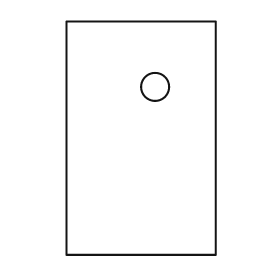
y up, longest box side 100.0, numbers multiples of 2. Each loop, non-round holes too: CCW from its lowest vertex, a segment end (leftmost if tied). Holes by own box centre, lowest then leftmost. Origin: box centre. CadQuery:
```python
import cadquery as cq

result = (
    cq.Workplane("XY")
    .moveTo(-32.0, -50.0)
    .lineTo(32.0, -50.0)
    .lineTo(32.0, 50.0)
    .lineTo(-32.0, 50.0)
    .close()
    .moveTo(6.0, 22.0)
    .circle(6.0)
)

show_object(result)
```